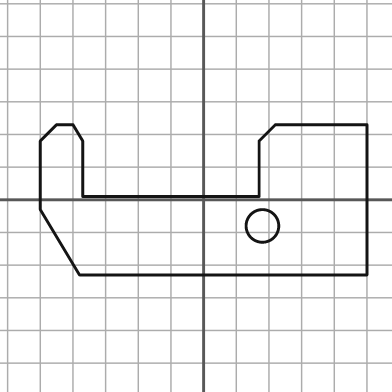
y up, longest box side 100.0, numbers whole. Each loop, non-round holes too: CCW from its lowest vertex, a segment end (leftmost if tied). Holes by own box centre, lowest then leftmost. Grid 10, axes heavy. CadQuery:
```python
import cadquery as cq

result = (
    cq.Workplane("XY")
    .moveTo(-38.0, -23.0)
    .lineTo(50.0, -23.0)
    .lineTo(50.0, 23.0)
    .lineTo(22.0, 23.0)
    .lineTo(17.0, 18.0)
    .lineTo(17.0, 1.0)
    .lineTo(-37.0, 1.0)
    .lineTo(-37.0, 18.0)
    .lineTo(-40.0, 23.0)
    .lineTo(-45.0, 23.0)
    .lineTo(-50.0, 18.0)
    .lineTo(-50.0, -3.0)
    .close()
    .moveTo(18.0, -8.0)
    .circle(5.0)
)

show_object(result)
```